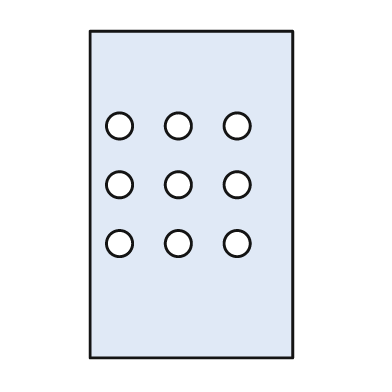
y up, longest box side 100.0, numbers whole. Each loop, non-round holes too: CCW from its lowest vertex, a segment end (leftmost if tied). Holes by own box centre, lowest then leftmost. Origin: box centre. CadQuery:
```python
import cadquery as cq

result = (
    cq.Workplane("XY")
    .moveTo(-31.0, -50.0)
    .lineTo(31.0, -50.0)
    .lineTo(31.0, 50.0)
    .lineTo(-31.0, 50.0)
    .close()
    .moveTo(-22.0, -15.0)
    .circle(4.0)
    .moveTo(-4.0, -15.0)
    .circle(4.0)
    .moveTo(14.0, -15.0)
    .circle(4.0)
    .moveTo(-22.0, 3.0)
    .circle(4.0)
    .moveTo(-4.0, 3.0)
    .circle(4.0)
    .moveTo(14.0, 3.0)
    .circle(4.0)
    .moveTo(-22.0, 21.0)
    .circle(4.0)
    .moveTo(-4.0, 21.0)
    .circle(4.0)
    .moveTo(14.0, 21.0)
    .circle(4.0)
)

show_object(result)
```